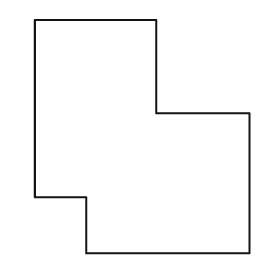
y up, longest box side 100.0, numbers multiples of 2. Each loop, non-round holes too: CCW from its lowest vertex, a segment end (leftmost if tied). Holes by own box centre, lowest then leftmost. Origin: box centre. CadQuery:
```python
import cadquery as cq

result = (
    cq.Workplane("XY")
    .moveTo(-24.0, -50.0)
    .lineTo(46.0, -50.0)
    .lineTo(46.0, 10.0)
    .lineTo(6.0, 10.0)
    .lineTo(6.0, 50.0)
    .lineTo(-46.0, 50.0)
    .lineTo(-46.0, -26.0)
    .lineTo(-24.0, -26.0)
    .close()
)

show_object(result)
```